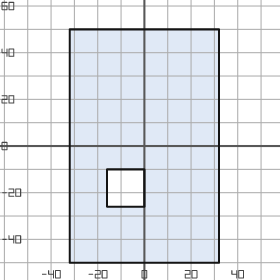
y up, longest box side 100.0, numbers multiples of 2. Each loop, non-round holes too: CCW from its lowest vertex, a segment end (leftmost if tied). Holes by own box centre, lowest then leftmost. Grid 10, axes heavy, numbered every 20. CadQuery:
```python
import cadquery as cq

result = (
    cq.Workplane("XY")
    .moveTo(-32.0, -50.0)
    .lineTo(32.0, -50.0)
    .lineTo(32.0, 50.0)
    .lineTo(-32.0, 50.0)
    .close()
    .moveTo(-16.0, -26.0)
    .lineTo(0.0, -26.0)
    .lineTo(0.0, -10.0)
    .lineTo(-16.0, -10.0)
    .close()
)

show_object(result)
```